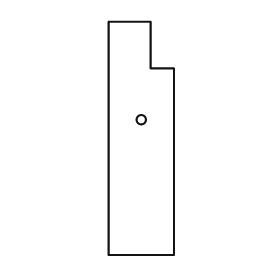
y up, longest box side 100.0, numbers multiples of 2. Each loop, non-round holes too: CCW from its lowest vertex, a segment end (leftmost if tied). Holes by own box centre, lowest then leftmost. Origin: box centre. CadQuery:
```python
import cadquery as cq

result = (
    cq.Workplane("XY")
    .moveTo(-14.0, -50.0)
    .lineTo(14.0, -50.0)
    .lineTo(14.0, 30.0)
    .lineTo(4.0, 30.0)
    .lineTo(4.0, 50.0)
    .lineTo(-14.0, 50.0)
    .close()
    .moveTo(0.0, 8.0)
    .circle(2.0)
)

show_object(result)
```